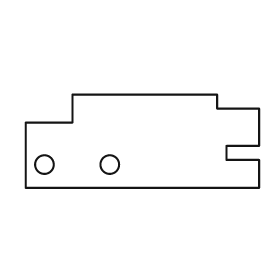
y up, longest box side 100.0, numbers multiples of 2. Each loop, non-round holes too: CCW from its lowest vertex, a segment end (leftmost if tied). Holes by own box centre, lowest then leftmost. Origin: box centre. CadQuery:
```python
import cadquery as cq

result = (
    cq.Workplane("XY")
    .moveTo(-50.0, -20.0)
    .lineTo(50.0, -20.0)
    .lineTo(50.0, -8.0)
    .lineTo(36.0, -8.0)
    .lineTo(36.0, -2.0)
    .lineTo(50.0, -2.0)
    .lineTo(50.0, 14.0)
    .lineTo(32.0, 14.0)
    .lineTo(32.0, 20.0)
    .lineTo(-30.0, 20.0)
    .lineTo(-30.0, 8.0)
    .lineTo(-50.0, 8.0)
    .close()
    .moveTo(-42.0, -10.0)
    .circle(4.0)
    .moveTo(-14.0, -10.0)
    .circle(4.0)
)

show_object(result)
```